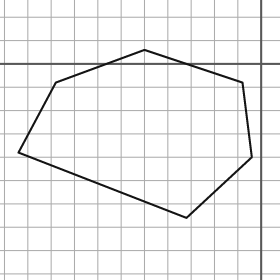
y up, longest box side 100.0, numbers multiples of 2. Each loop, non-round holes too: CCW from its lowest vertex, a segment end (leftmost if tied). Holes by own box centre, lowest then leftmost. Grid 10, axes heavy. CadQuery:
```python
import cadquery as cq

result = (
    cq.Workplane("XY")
    .moveTo(-32.0, -66.0)
    .lineTo(-4.0, -40.0)
    .lineTo(-8.0, -8.0)
    .lineTo(-50.0, 6.0)
    .lineTo(-88.0, -8.0)
    .lineTo(-104.0, -38.0)
    .close()
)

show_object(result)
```